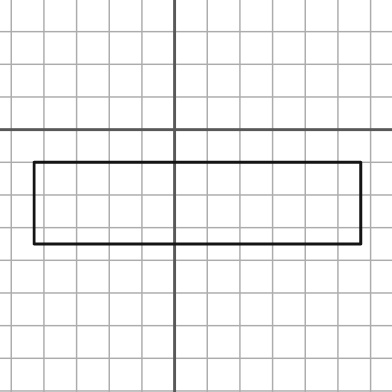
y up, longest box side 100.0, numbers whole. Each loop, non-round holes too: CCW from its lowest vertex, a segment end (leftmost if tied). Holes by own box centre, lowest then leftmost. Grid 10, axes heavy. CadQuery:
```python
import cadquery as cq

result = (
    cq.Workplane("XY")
    .moveTo(-43.0, -35.0)
    .lineTo(57.0, -35.0)
    .lineTo(57.0, -10.0)
    .lineTo(-43.0, -10.0)
    .close()
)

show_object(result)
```